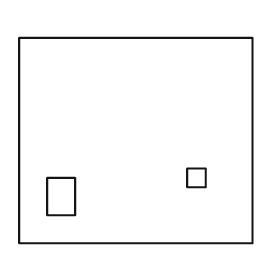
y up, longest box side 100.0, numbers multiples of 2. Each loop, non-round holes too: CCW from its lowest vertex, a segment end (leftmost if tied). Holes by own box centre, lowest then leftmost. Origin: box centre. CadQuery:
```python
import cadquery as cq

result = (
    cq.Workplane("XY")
    .moveTo(-50.0, -44.0)
    .lineTo(50.0, -44.0)
    .lineTo(50.0, 44.0)
    .lineTo(-50.0, 44.0)
    .close()
    .moveTo(-38.0, -32.0)
    .lineTo(-26.0, -32.0)
    .lineTo(-26.0, -16.0)
    .lineTo(-38.0, -16.0)
    .close()
    .moveTo(22.0, -20.0)
    .lineTo(30.0, -20.0)
    .lineTo(30.0, -12.0)
    .lineTo(22.0, -12.0)
    .close()
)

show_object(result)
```